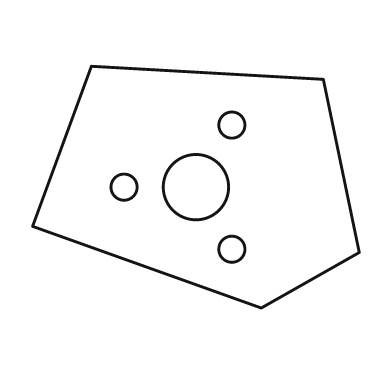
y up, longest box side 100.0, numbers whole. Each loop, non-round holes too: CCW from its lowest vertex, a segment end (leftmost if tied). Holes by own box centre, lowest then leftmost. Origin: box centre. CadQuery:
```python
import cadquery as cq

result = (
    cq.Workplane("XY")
    .moveTo(20.0, -37.0)
    .lineTo(50.0, -20.0)
    .lineTo(39.0, 33.0)
    .lineTo(-32.0, 37.0)
    .lineTo(-50.0, -12.0)
    .close()
    .moveTo(11.0, -19.0)
    .circle(4.0)
    .moveTo(-22.0, 0.0)
    .circle(4.0)
    .moveTo(0.0, 0.0)
    .circle(10.0)
    .moveTo(11.0, 19.0)
    .circle(4.0)
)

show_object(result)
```